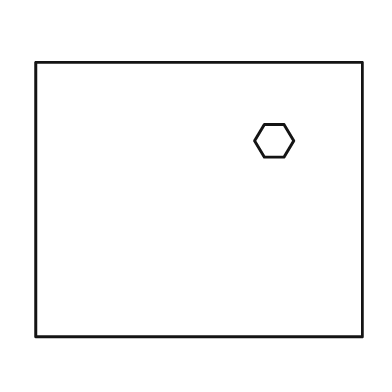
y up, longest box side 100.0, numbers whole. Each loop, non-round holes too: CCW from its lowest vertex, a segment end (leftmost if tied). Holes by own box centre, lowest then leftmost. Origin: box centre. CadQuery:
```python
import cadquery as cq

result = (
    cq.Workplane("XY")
    .moveTo(-50.0, -42.0)
    .lineTo(50.0, -42.0)
    .lineTo(50.0, 42.0)
    .lineTo(-50.0, 42.0)
    .close()
    .moveTo(20.0, 13.0)
    .lineTo(26.0, 13.0)
    .lineTo(29.0, 18.0)
    .lineTo(26.0, 23.0)
    .lineTo(20.0, 23.0)
    .lineTo(17.0, 18.0)
    .close()
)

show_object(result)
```